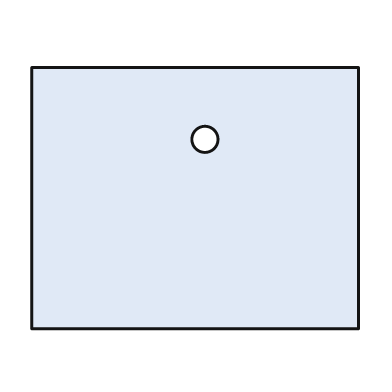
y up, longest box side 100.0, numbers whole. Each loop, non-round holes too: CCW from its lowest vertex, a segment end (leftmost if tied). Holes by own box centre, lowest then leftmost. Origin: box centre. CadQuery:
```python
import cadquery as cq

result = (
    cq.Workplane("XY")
    .moveTo(-50.0, -40.0)
    .lineTo(50.0, -40.0)
    .lineTo(50.0, 40.0)
    .lineTo(-50.0, 40.0)
    .close()
    .moveTo(3.0, 18.0)
    .circle(4.0)
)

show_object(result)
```